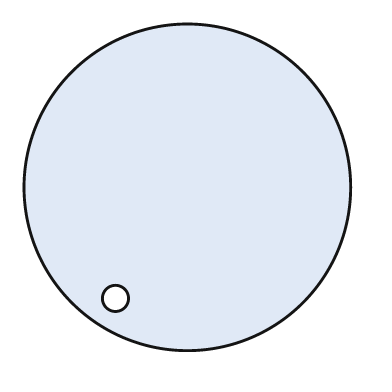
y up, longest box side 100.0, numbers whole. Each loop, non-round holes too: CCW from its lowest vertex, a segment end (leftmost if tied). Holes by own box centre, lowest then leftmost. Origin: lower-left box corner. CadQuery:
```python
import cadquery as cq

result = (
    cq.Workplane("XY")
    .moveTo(50.0, 50.0)
    .circle(50.0)
    .moveTo(28.0, 16.0)
    .circle(4.0)
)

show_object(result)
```